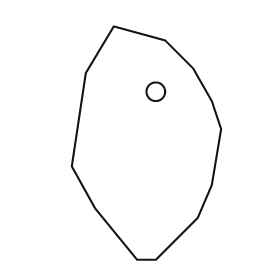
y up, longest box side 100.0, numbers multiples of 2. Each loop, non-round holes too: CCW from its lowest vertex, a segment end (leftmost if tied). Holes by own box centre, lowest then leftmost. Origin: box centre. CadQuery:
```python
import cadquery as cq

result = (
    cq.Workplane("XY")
    .moveTo(-4.0, -50.0)
    .lineTo(4.0, -50.0)
    .lineTo(22.0, -32.0)
    .lineTo(28.0, -18.0)
    .lineTo(32.0, 6.0)
    .lineTo(28.0, 18.0)
    .lineTo(20.0, 32.0)
    .lineTo(8.0, 44.0)
    .lineTo(-14.0, 50.0)
    .lineTo(-26.0, 30.0)
    .lineTo(-32.0, -10.0)
    .lineTo(-22.0, -28.0)
    .close()
    .moveTo(4.0, 22.0)
    .circle(4.0)
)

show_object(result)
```